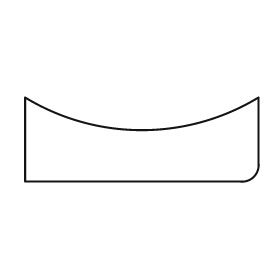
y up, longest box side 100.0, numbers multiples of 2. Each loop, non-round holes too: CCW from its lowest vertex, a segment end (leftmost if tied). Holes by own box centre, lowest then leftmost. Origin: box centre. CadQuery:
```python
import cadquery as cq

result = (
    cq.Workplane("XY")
    .moveTo(-50.0, -18.0)
    .lineTo(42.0, -18.0)
    .threePointArc((48.0, -16.0), (50.0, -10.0))
    .lineTo(50.0, 18.0)
    .threePointArc((0.0, 4.0), (-50.0, 18.0))
    .close()
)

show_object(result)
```